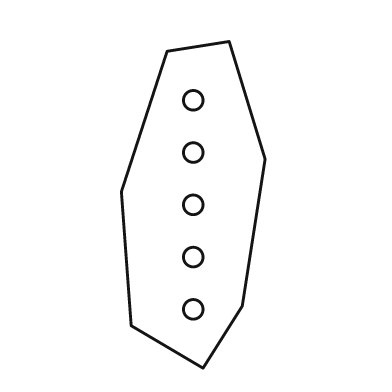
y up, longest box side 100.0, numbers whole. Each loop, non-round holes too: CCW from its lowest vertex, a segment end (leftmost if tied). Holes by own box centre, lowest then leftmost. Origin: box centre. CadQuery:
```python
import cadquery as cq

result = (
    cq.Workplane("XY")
    .moveTo(3.0, -50.0)
    .lineTo(15.0, -31.0)
    .lineTo(22.0, 14.0)
    .lineTo(11.0, 50.0)
    .lineTo(-8.0, 47.0)
    .lineTo(-22.0, 4.0)
    .lineTo(-19.0, -37.0)
    .close()
    .moveTo(0.0, -32.0)
    .circle(3.0)
    .moveTo(0.0, -16.0)
    .circle(3.0)
    .moveTo(0.0, 0.0)
    .circle(3.0)
    .moveTo(0.0, 16.0)
    .circle(3.0)
    .moveTo(0.0, 32.0)
    .circle(3.0)
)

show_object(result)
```